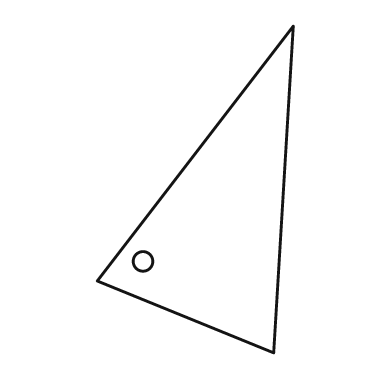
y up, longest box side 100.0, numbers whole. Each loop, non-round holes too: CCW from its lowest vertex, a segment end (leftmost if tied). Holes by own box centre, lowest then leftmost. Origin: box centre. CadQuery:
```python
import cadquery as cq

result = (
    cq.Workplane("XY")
    .moveTo(24.0, -50.0)
    .lineTo(30.0, 50.0)
    .lineTo(-30.0, -28.0)
    .close()
    .moveTo(-16.0, -22.0)
    .circle(3.0)
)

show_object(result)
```